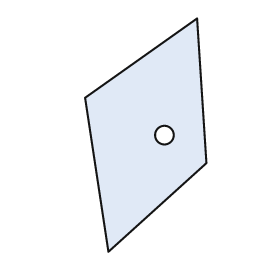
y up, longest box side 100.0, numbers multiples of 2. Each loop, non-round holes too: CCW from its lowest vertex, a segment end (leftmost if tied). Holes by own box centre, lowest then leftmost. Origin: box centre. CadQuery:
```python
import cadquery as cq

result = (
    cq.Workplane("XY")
    .moveTo(-16.0, -50.0)
    .lineTo(26.0, -12.0)
    .lineTo(22.0, 50.0)
    .lineTo(-26.0, 16.0)
    .close()
    .moveTo(8.0, 0.0)
    .circle(4.0)
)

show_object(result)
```